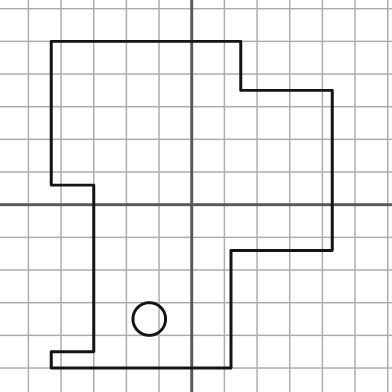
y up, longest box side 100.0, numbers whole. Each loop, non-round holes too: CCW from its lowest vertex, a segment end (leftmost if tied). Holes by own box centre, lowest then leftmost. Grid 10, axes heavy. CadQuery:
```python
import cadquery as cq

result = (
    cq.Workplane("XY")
    .moveTo(-43.0, -50.0)
    .lineTo(12.0, -50.0)
    .lineTo(12.0, -14.0)
    .lineTo(43.0, -14.0)
    .lineTo(43.0, 35.0)
    .lineTo(15.0, 35.0)
    .lineTo(15.0, 50.0)
    .lineTo(-43.0, 50.0)
    .lineTo(-43.0, 6.0)
    .lineTo(-30.0, 6.0)
    .lineTo(-30.0, -45.0)
    .lineTo(-43.0, -45.0)
    .close()
    .moveTo(-13.0, -35.0)
    .circle(5.0)
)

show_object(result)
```